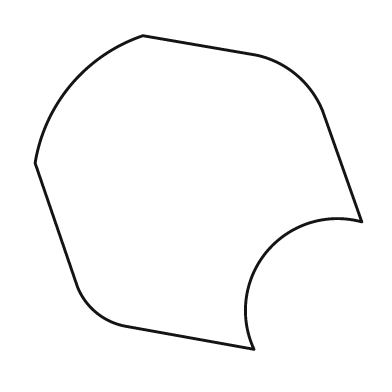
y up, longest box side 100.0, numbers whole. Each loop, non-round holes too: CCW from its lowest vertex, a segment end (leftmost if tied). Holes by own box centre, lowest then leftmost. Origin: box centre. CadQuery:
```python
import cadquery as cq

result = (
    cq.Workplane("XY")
    .moveTo(17.0, -48.0)
    .threePointArc((21.0, -18.0), (50.0, -9.0))
    .lineTo(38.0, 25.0)
    .threePointArc((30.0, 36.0), (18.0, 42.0))
    .lineTo(-17.0, 48.0)
    .threePointArc((-39.0, 33.0), (-50.0, 9.0))
    .lineTo(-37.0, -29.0)
    .threePointArc((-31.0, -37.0), (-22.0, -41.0))
    .close()
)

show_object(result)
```